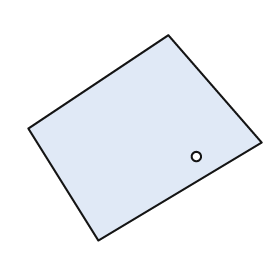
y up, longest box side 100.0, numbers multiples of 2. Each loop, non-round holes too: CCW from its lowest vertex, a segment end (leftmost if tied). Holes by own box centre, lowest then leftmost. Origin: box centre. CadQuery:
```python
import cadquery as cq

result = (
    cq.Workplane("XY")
    .moveTo(-20.0, -44.0)
    .lineTo(50.0, -2.0)
    .lineTo(10.0, 44.0)
    .lineTo(-50.0, 4.0)
    .close()
    .moveTo(22.0, -8.0)
    .circle(2.0)
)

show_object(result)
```